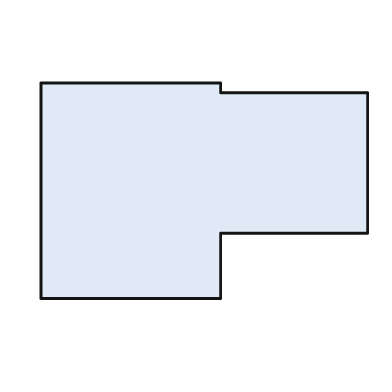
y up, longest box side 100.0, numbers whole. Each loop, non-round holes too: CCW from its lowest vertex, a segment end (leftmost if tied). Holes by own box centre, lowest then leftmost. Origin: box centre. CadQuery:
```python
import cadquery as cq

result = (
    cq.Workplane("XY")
    .moveTo(-50.0, -33.0)
    .lineTo(5.0, -33.0)
    .lineTo(5.0, -13.0)
    .lineTo(50.0, -13.0)
    .lineTo(50.0, 30.0)
    .lineTo(5.0, 30.0)
    .lineTo(5.0, 33.0)
    .lineTo(-50.0, 33.0)
    .close()
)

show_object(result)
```